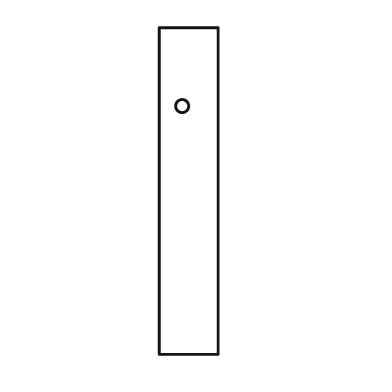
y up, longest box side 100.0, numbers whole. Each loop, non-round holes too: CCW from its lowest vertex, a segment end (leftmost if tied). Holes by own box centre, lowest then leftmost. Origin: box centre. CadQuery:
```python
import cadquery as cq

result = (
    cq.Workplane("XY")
    .moveTo(-9.0, -50.0)
    .lineTo(9.0, -50.0)
    .lineTo(9.0, 50.0)
    .lineTo(-9.0, 50.0)
    .close()
    .moveTo(-2.0, 26.0)
    .circle(2.0)
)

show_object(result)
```